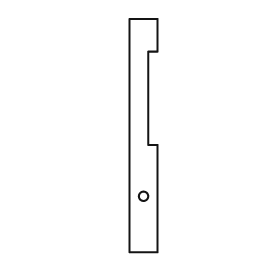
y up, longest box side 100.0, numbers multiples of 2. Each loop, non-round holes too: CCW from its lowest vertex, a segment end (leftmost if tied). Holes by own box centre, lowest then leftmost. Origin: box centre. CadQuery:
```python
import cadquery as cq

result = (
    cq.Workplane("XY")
    .moveTo(-6.0, -50.0)
    .lineTo(6.0, -50.0)
    .lineTo(6.0, -4.0)
    .lineTo(2.0, -4.0)
    .lineTo(2.0, 36.0)
    .lineTo(6.0, 36.0)
    .lineTo(6.0, 50.0)
    .lineTo(-6.0, 50.0)
    .close()
    .moveTo(0.0, -26.0)
    .circle(2.0)
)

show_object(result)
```